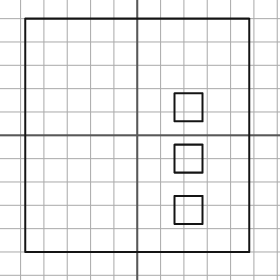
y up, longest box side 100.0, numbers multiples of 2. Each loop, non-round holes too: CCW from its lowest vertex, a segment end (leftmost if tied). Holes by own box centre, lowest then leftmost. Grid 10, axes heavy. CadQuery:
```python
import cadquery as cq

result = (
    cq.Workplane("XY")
    .moveTo(-48.0, -50.0)
    .lineTo(48.0, -50.0)
    .lineTo(48.0, 50.0)
    .lineTo(-48.0, 50.0)
    .close()
    .moveTo(16.0, -38.0)
    .lineTo(28.0, -38.0)
    .lineTo(28.0, -26.0)
    .lineTo(16.0, -26.0)
    .close()
    .moveTo(16.0, -16.0)
    .lineTo(28.0, -16.0)
    .lineTo(28.0, -4.0)
    .lineTo(16.0, -4.0)
    .close()
    .moveTo(16.0, 6.0)
    .lineTo(28.0, 6.0)
    .lineTo(28.0, 18.0)
    .lineTo(16.0, 18.0)
    .close()
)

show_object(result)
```